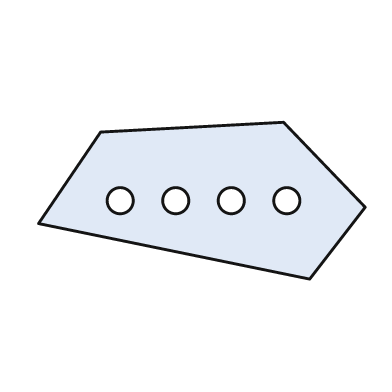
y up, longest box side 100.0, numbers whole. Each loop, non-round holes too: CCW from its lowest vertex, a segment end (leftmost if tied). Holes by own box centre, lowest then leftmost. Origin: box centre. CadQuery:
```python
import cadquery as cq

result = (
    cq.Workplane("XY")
    .moveTo(33.0, -24.0)
    .lineTo(50.0, -2.0)
    .lineTo(25.0, 24.0)
    .lineTo(-31.0, 21.0)
    .lineTo(-50.0, -7.0)
    .close()
    .moveTo(-25.0, 0.0)
    .circle(4.0)
    .moveTo(-8.0, 0.0)
    .circle(4.0)
    .moveTo(9.0, 0.0)
    .circle(4.0)
    .moveTo(26.0, 0.0)
    .circle(4.0)
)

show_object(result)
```